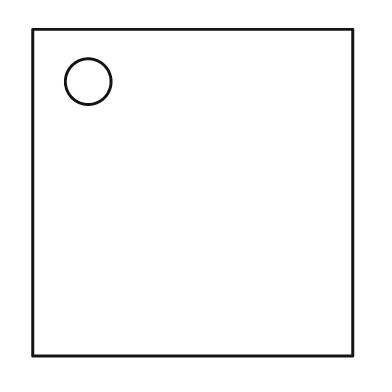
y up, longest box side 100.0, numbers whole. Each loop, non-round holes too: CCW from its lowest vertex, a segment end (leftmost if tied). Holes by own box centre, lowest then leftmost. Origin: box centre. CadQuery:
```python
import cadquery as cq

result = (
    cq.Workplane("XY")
    .moveTo(-49.0, -50.0)
    .lineTo(49.0, -50.0)
    .lineTo(49.0, 50.0)
    .lineTo(-49.0, 50.0)
    .close()
    .moveTo(-32.0, 34.0)
    .circle(7.0)
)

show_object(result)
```